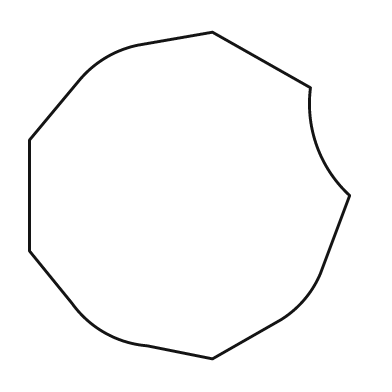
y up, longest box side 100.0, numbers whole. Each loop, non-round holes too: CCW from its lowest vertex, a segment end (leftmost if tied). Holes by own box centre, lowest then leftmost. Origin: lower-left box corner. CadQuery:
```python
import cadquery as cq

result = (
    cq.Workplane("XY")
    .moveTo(56.0, 0.0)
    .lineTo(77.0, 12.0)
    .threePointArc((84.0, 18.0), (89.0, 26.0))
    .lineTo(98.0, 50.0)
    .threePointArc((88.0, 65.0), (86.0, 83.0))
    .lineTo(56.0, 100.0)
    .lineTo(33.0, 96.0)
    .threePointArc((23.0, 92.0), (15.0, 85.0))
    .lineTo(0.0, 67.0)
    .lineTo(0.0, 33.0)
    .lineTo(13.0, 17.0)
    .threePointArc((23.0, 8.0), (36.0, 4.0))
    .close()
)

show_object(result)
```